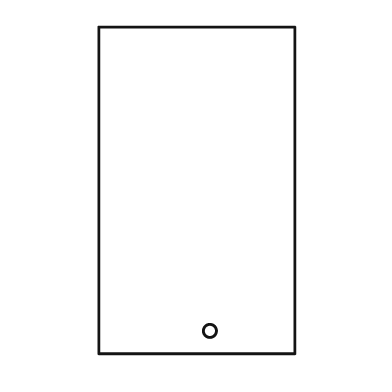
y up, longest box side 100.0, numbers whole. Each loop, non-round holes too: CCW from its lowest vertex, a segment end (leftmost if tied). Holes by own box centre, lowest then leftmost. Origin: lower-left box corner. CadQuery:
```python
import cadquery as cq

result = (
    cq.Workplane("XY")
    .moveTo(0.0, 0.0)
    .lineTo(60.0, 0.0)
    .lineTo(60.0, 100.0)
    .lineTo(0.0, 100.0)
    .close()
    .moveTo(34.0, 7.0)
    .circle(2.0)
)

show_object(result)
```